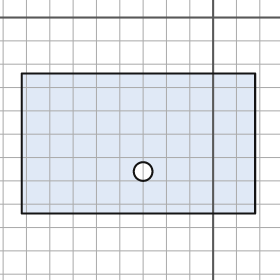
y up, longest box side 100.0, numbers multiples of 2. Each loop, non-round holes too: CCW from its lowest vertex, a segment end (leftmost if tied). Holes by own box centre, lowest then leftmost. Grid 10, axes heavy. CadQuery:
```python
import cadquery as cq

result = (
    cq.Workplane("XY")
    .moveTo(-82.0, -84.0)
    .lineTo(18.0, -84.0)
    .lineTo(18.0, -24.0)
    .lineTo(-82.0, -24.0)
    .close()
    .moveTo(-30.0, -66.0)
    .circle(4.0)
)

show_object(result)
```